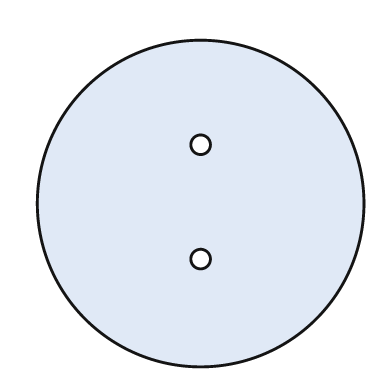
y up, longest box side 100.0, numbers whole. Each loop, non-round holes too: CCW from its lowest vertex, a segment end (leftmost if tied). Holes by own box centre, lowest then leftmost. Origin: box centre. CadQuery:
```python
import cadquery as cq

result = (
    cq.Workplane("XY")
    .moveTo(0.0, 0.0)
    .circle(50.0)
    .moveTo(0.0, -17.0)
    .circle(3.0)
    .moveTo(0.0, 18.0)
    .circle(3.0)
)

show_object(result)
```